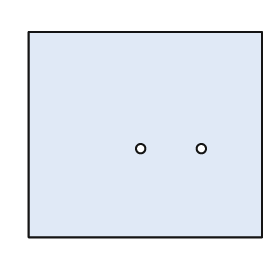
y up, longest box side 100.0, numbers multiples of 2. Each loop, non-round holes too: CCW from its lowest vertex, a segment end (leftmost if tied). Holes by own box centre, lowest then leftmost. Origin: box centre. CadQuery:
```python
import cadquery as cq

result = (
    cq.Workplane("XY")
    .moveTo(-50.0, -44.0)
    .lineTo(50.0, -44.0)
    .lineTo(50.0, 44.0)
    .lineTo(-50.0, 44.0)
    .close()
    .moveTo(-2.0, -6.0)
    .circle(2.0)
    .moveTo(24.0, -6.0)
    .circle(2.0)
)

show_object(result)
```